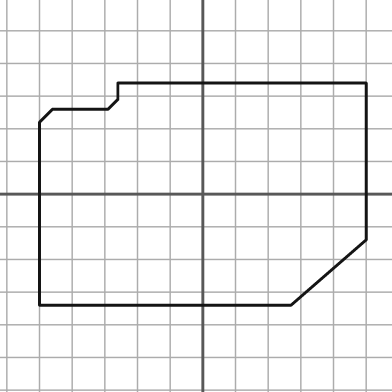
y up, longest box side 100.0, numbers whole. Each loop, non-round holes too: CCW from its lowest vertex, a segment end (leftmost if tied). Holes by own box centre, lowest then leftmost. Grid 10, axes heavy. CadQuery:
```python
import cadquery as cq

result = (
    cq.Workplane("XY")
    .moveTo(-50.0, -34.0)
    .lineTo(27.0, -34.0)
    .lineTo(50.0, -14.0)
    .lineTo(50.0, 34.0)
    .lineTo(-26.0, 34.0)
    .lineTo(-26.0, 29.0)
    .lineTo(-29.0, 26.0)
    .lineTo(-46.0, 26.0)
    .lineTo(-50.0, 22.0)
    .close()
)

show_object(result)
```